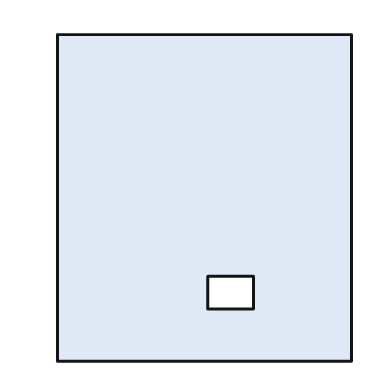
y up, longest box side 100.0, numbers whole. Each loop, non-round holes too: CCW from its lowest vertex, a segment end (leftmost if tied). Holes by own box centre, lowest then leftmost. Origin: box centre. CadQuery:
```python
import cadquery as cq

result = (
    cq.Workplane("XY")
    .moveTo(-45.0, -50.0)
    .lineTo(45.0, -50.0)
    .lineTo(45.0, 50.0)
    .lineTo(-45.0, 50.0)
    .close()
    .moveTo(1.0, -34.0)
    .lineTo(15.0, -34.0)
    .lineTo(15.0, -24.0)
    .lineTo(1.0, -24.0)
    .close()
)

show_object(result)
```